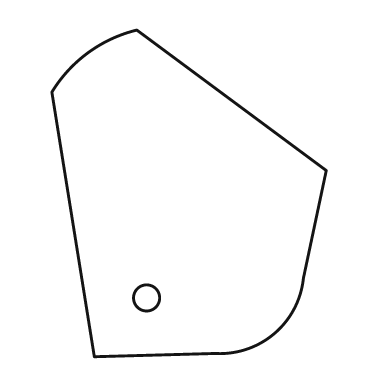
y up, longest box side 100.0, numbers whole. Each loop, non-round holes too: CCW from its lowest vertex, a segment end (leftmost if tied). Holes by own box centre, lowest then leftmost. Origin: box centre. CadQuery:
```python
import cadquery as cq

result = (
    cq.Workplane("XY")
    .moveTo(-29.0, -50.0)
    .lineTo(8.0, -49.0)
    .threePointArc((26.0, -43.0), (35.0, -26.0))
    .lineTo(42.0, 7.0)
    .lineTo(-16.0, 50.0)
    .threePointArc((-31.0, 43.0), (-42.0, 31.0))
    .close()
    .moveTo(-13.0, -32.0)
    .circle(4.0)
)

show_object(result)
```